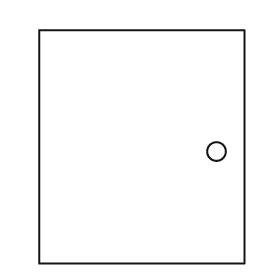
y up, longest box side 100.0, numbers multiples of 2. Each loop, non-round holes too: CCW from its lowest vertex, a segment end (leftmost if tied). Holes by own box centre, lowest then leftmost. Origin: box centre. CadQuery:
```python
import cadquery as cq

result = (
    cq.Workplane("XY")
    .moveTo(-44.0, -50.0)
    .lineTo(44.0, -50.0)
    .lineTo(44.0, 50.0)
    .lineTo(-44.0, 50.0)
    .close()
    .moveTo(32.0, -2.0)
    .circle(4.0)
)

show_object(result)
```